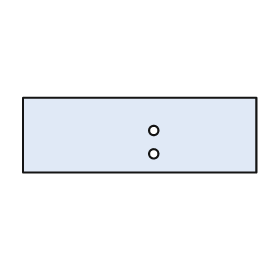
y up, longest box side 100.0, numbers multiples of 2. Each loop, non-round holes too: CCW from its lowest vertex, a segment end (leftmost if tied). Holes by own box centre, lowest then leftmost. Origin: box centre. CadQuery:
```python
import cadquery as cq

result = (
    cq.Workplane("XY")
    .moveTo(-50.0, -16.0)
    .lineTo(50.0, -16.0)
    .lineTo(50.0, 16.0)
    .lineTo(-50.0, 16.0)
    .close()
    .moveTo(6.0, -8.0)
    .circle(2.0)
    .moveTo(6.0, 2.0)
    .circle(2.0)
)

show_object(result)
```